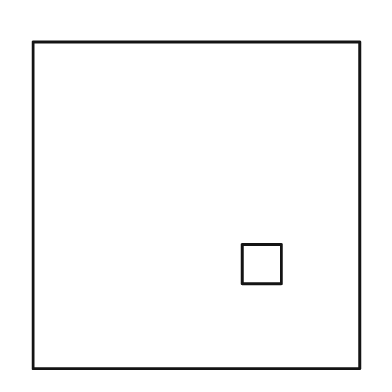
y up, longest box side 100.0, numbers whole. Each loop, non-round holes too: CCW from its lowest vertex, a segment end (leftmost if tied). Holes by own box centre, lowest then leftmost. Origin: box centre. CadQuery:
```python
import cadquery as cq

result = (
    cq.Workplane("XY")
    .moveTo(-50.0, -50.0)
    .lineTo(50.0, -50.0)
    .lineTo(50.0, 50.0)
    .lineTo(-50.0, 50.0)
    .close()
    .moveTo(14.0, -24.0)
    .lineTo(26.0, -24.0)
    .lineTo(26.0, -12.0)
    .lineTo(14.0, -12.0)
    .close()
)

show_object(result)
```